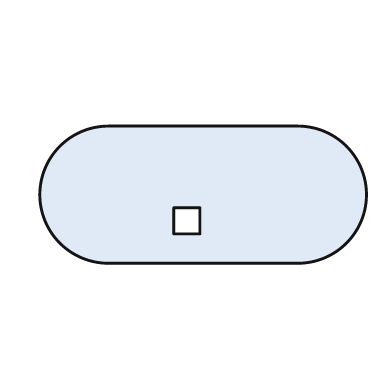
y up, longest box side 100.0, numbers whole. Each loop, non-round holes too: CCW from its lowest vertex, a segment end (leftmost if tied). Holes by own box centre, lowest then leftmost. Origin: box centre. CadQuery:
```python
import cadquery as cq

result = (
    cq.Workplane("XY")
    .moveTo(-29.0, -21.0)
    .lineTo(29.0, -21.0)
    .threePointArc((50.0, 0.0), (29.0, 21.0))
    .lineTo(-29.0, 21.0)
    .threePointArc((-50.0, 0.0), (-29.0, -21.0))
    .close()
    .moveTo(-9.0, -12.0)
    .lineTo(-1.0, -12.0)
    .lineTo(-1.0, -4.0)
    .lineTo(-9.0, -4.0)
    .close()
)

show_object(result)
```